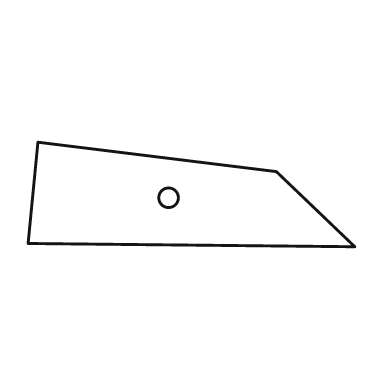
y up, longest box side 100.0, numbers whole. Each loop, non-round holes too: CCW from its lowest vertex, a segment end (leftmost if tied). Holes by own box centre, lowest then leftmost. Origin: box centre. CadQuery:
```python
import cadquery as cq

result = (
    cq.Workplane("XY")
    .moveTo(50.0, -16.0)
    .lineTo(26.0, 7.0)
    .lineTo(-47.0, 16.0)
    .lineTo(-50.0, -15.0)
    .close()
    .moveTo(-7.0, -1.0)
    .circle(3.0)
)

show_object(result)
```